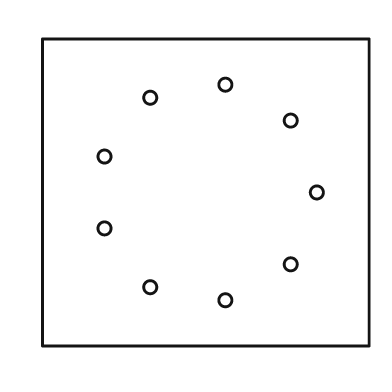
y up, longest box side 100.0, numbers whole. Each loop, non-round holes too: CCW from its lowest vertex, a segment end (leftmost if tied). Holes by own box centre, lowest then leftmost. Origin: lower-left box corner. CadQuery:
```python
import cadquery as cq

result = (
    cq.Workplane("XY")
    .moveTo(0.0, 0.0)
    .lineTo(100.0, 0.0)
    .lineTo(100.0, 94.0)
    .lineTo(0.0, 94.0)
    .close()
    .moveTo(56.0, 14.0)
    .circle(2.0)
    .moveTo(33.0, 18.0)
    .circle(2.0)
    .moveTo(76.0, 25.0)
    .circle(2.0)
    .moveTo(19.0, 36.0)
    .circle(2.0)
    .moveTo(84.0, 47.0)
    .circle(2.0)
    .moveTo(19.0, 58.0)
    .circle(2.0)
    .moveTo(76.0, 69.0)
    .circle(2.0)
    .moveTo(33.0, 76.0)
    .circle(2.0)
    .moveTo(56.0, 80.0)
    .circle(2.0)
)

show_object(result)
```